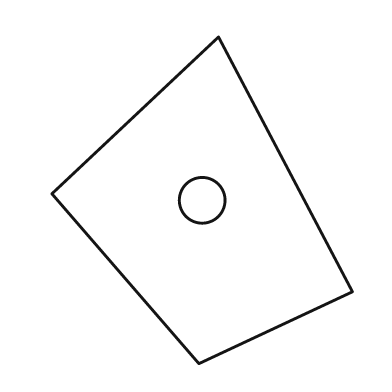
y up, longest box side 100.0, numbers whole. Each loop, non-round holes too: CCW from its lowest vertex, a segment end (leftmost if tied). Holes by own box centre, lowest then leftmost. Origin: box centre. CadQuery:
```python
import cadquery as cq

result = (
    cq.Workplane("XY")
    .moveTo(-1.0, -50.0)
    .lineTo(46.0, -28.0)
    .lineTo(5.0, 50.0)
    .lineTo(-46.0, 2.0)
    .close()
    .moveTo(0.0, 0.0)
    .circle(7.0)
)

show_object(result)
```